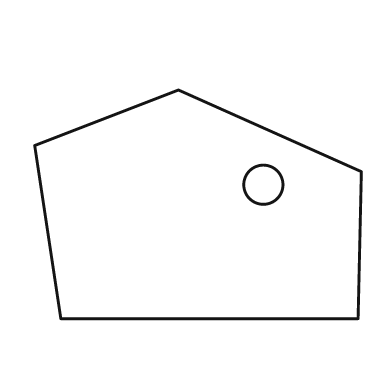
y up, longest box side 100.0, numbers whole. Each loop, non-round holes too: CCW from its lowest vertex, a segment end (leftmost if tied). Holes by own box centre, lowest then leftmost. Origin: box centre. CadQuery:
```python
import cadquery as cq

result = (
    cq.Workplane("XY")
    .moveTo(-42.0, -35.0)
    .lineTo(49.0, -35.0)
    .lineTo(50.0, 10.0)
    .lineTo(-6.0, 35.0)
    .lineTo(-50.0, 18.0)
    .close()
    .moveTo(20.0, 6.0)
    .circle(6.0)
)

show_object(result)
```